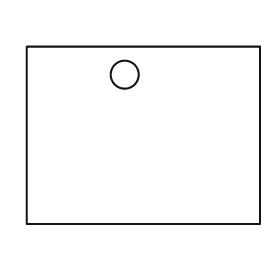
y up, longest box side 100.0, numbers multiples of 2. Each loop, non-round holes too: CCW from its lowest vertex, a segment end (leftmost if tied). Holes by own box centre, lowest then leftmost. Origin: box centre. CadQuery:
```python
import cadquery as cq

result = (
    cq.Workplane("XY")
    .moveTo(-50.0, -38.0)
    .lineTo(50.0, -38.0)
    .lineTo(50.0, 38.0)
    .lineTo(-50.0, 38.0)
    .close()
    .moveTo(-8.0, 26.0)
    .circle(6.0)
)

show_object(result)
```